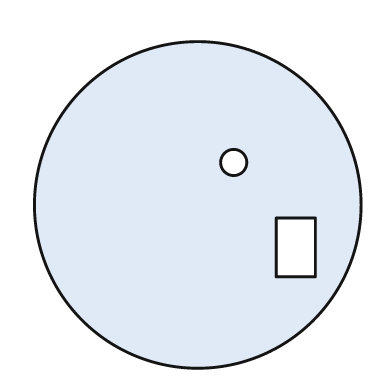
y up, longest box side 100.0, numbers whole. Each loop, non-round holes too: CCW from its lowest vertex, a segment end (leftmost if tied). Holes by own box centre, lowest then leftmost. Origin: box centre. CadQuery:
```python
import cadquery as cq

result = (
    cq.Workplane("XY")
    .moveTo(0.0, 0.0)
    .circle(50.0)
    .moveTo(24.0, -22.0)
    .lineTo(36.0, -22.0)
    .lineTo(36.0, -4.0)
    .lineTo(24.0, -4.0)
    .close()
    .moveTo(11.0, 13.0)
    .circle(4.0)
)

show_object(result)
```